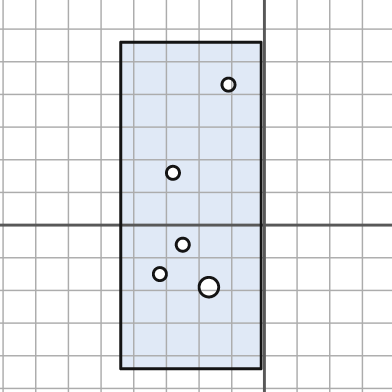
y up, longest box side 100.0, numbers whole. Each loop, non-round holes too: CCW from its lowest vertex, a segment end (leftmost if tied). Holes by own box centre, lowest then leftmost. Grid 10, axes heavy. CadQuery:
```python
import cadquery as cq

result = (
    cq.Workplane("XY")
    .moveTo(-44.0, -44.0)
    .lineTo(-1.0, -44.0)
    .lineTo(-1.0, 56.0)
    .lineTo(-44.0, 56.0)
    .close()
    .moveTo(-17.0, -19.0)
    .circle(3.0)
    .moveTo(-32.0, -15.0)
    .circle(2.0)
    .moveTo(-25.0, -6.0)
    .circle(2.0)
    .moveTo(-28.0, 16.0)
    .circle(2.0)
    .moveTo(-11.0, 43.0)
    .circle(2.0)
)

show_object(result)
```